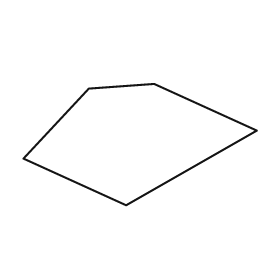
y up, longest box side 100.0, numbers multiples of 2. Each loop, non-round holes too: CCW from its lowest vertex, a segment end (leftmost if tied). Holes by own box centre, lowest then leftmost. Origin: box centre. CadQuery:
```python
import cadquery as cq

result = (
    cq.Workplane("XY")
    .moveTo(-6.0, -26.0)
    .lineTo(50.0, 6.0)
    .lineTo(6.0, 26.0)
    .lineTo(-22.0, 24.0)
    .lineTo(-50.0, -6.0)
    .close()
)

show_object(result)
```